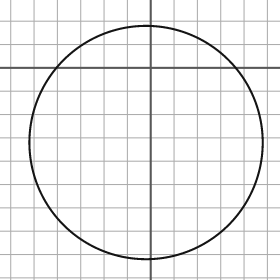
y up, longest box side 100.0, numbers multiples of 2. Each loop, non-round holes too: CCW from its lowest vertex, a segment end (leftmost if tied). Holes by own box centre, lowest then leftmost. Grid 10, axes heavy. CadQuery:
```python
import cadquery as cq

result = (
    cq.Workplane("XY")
    .moveTo(-2.0, -32.0)
    .circle(50.0)
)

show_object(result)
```